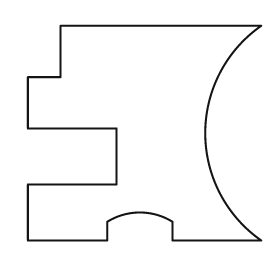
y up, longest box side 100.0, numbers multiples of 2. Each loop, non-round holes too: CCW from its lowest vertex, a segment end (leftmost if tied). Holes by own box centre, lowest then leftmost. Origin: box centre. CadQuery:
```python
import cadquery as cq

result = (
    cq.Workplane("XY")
    .moveTo(-50.0, -46.0)
    .lineTo(-16.0, -46.0)
    .lineTo(-16.0, -38.0)
    .threePointArc((-2.0, -34.0), (12.0, -38.0))
    .lineTo(12.0, -46.0)
    .lineTo(50.0, -46.0)
    .threePointArc((26.0, 0.0), (50.0, 46.0))
    .lineTo(-36.0, 46.0)
    .lineTo(-36.0, 24.0)
    .lineTo(-50.0, 24.0)
    .lineTo(-50.0, 2.0)
    .lineTo(-12.0, 2.0)
    .lineTo(-12.0, -22.0)
    .lineTo(-50.0, -22.0)
    .close()
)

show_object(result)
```